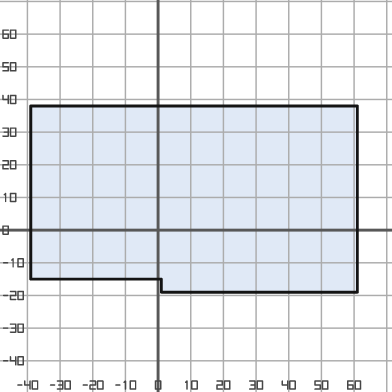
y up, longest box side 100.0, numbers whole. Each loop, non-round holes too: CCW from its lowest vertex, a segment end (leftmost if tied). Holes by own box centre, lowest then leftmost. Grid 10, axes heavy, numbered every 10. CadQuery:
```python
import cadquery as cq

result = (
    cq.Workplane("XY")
    .moveTo(1.0, -19.0)
    .lineTo(61.0, -19.0)
    .lineTo(61.0, 38.0)
    .lineTo(-39.0, 38.0)
    .lineTo(-39.0, -15.0)
    .lineTo(1.0, -15.0)
    .close()
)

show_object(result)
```